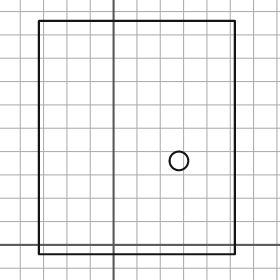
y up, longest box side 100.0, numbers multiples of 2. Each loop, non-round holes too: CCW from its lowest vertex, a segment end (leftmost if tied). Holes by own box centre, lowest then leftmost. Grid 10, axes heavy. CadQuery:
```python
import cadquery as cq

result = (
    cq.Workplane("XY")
    .moveTo(-32.0, -4.0)
    .lineTo(52.0, -4.0)
    .lineTo(52.0, 96.0)
    .lineTo(-32.0, 96.0)
    .close()
    .moveTo(28.0, 36.0)
    .circle(4.0)
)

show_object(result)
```